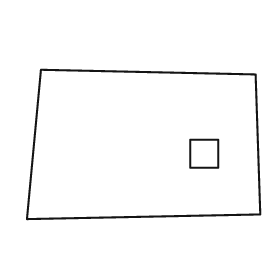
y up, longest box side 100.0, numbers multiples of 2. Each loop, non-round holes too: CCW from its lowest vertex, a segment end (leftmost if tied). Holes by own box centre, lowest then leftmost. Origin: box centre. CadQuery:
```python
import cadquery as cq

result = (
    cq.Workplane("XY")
    .moveTo(-50.0, -32.0)
    .lineTo(50.0, -30.0)
    .lineTo(48.0, 30.0)
    .lineTo(-44.0, 32.0)
    .close()
    .moveTo(20.0, -10.0)
    .lineTo(32.0, -10.0)
    .lineTo(32.0, 2.0)
    .lineTo(20.0, 2.0)
    .close()
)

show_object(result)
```